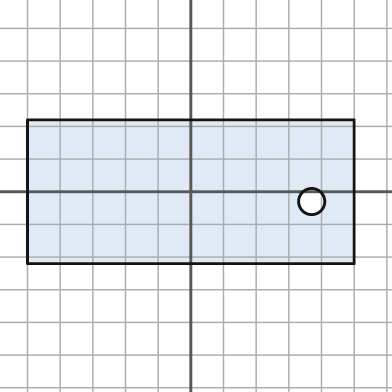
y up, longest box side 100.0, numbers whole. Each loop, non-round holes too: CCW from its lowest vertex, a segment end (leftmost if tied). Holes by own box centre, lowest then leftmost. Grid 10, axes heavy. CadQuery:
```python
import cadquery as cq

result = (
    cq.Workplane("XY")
    .moveTo(-50.0, -22.0)
    .lineTo(50.0, -22.0)
    .lineTo(50.0, 22.0)
    .lineTo(-50.0, 22.0)
    .close()
    .moveTo(37.0, -3.0)
    .circle(4.0)
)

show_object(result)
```